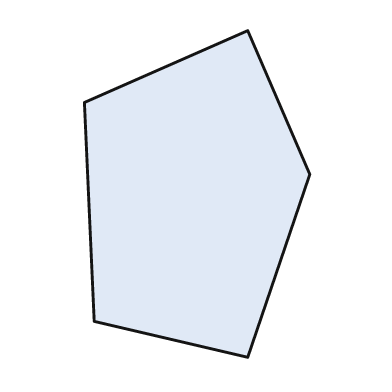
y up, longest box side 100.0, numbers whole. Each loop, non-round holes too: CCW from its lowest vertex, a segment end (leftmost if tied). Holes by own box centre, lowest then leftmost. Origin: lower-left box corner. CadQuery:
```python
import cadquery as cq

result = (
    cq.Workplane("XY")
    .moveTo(50.0, 0.0)
    .lineTo(69.0, 56.0)
    .lineTo(50.0, 100.0)
    .lineTo(0.0, 78.0)
    .lineTo(3.0, 11.0)
    .close()
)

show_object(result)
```